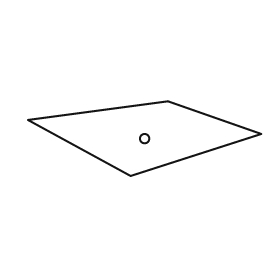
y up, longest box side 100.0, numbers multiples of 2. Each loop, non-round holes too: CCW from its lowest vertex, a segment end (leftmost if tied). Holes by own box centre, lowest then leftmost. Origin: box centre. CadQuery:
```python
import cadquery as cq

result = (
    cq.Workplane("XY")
    .moveTo(-6.0, -16.0)
    .lineTo(50.0, 2.0)
    .lineTo(10.0, 16.0)
    .lineTo(-50.0, 8.0)
    .close()
    .moveTo(0.0, 0.0)
    .circle(2.0)
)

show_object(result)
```